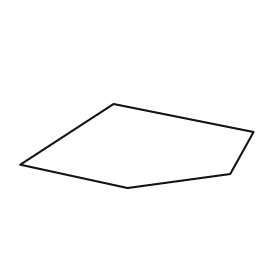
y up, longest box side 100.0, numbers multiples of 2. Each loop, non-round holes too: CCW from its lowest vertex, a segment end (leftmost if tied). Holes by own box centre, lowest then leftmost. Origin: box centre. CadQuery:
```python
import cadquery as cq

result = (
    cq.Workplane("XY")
    .moveTo(-4.0, -18.0)
    .lineTo(40.0, -12.0)
    .lineTo(50.0, 6.0)
    .lineTo(-10.0, 18.0)
    .lineTo(-50.0, -8.0)
    .close()
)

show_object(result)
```